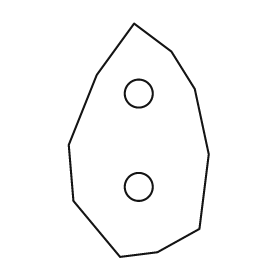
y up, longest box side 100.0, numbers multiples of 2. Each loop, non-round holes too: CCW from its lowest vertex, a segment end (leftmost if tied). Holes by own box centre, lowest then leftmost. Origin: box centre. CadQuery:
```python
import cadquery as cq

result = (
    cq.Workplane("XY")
    .moveTo(-8.0, -50.0)
    .lineTo(8.0, -48.0)
    .lineTo(26.0, -38.0)
    .lineTo(30.0, -6.0)
    .lineTo(24.0, 22.0)
    .lineTo(14.0, 38.0)
    .lineTo(-2.0, 50.0)
    .lineTo(-18.0, 28.0)
    .lineTo(-30.0, -2.0)
    .lineTo(-28.0, -26.0)
    .close()
    .moveTo(0.0, -20.0)
    .circle(6.0)
    .moveTo(0.0, 20.0)
    .circle(6.0)
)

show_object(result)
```